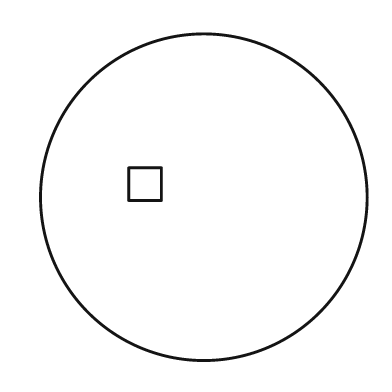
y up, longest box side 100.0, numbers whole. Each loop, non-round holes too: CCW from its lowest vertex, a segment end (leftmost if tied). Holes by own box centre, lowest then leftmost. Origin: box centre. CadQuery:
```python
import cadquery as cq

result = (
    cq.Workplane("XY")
    .moveTo(0.0, 0.0)
    .circle(50.0)
    .moveTo(-23.0, -1.0)
    .lineTo(-13.0, -1.0)
    .lineTo(-13.0, 9.0)
    .lineTo(-23.0, 9.0)
    .close()
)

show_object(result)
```